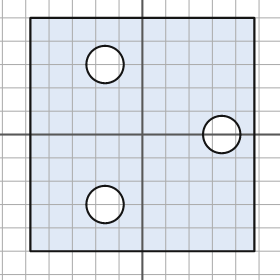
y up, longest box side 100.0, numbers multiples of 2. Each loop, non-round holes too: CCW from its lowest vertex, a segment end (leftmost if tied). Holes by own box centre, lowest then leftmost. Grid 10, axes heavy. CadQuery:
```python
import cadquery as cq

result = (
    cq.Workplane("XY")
    .moveTo(-48.0, -50.0)
    .lineTo(48.0, -50.0)
    .lineTo(48.0, 50.0)
    .lineTo(-48.0, 50.0)
    .close()
    .moveTo(-16.0, -30.0)
    .circle(8.0)
    .moveTo(34.0, 0.0)
    .circle(8.0)
    .moveTo(-16.0, 30.0)
    .circle(8.0)
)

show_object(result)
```